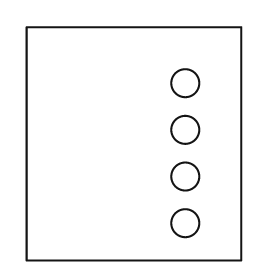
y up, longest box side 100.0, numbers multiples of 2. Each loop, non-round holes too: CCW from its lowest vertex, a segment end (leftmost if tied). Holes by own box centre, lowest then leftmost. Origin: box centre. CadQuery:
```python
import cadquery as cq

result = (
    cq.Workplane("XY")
    .moveTo(-46.0, -50.0)
    .lineTo(46.0, -50.0)
    .lineTo(46.0, 50.0)
    .lineTo(-46.0, 50.0)
    .close()
    .moveTo(22.0, -34.0)
    .circle(6.0)
    .moveTo(22.0, -14.0)
    .circle(6.0)
    .moveTo(22.0, 6.0)
    .circle(6.0)
    .moveTo(22.0, 26.0)
    .circle(6.0)
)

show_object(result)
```